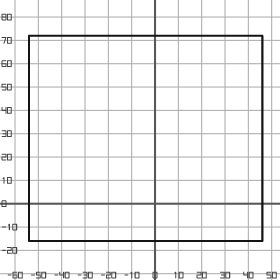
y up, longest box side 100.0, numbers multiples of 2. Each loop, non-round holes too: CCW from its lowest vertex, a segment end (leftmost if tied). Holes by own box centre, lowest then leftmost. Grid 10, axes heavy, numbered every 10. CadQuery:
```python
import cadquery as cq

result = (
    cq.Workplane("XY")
    .moveTo(-54.0, -16.0)
    .lineTo(46.0, -16.0)
    .lineTo(46.0, 72.0)
    .lineTo(-54.0, 72.0)
    .close()
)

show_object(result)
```